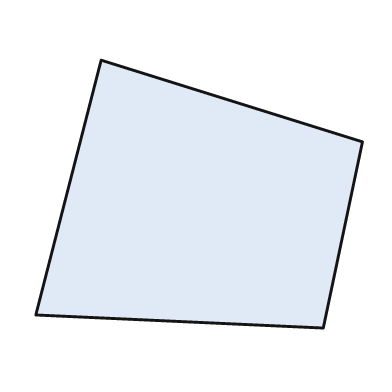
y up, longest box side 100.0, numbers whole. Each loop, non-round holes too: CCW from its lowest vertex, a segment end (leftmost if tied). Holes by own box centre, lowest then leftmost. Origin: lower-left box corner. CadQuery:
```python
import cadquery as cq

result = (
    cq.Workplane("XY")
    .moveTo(88.0, 0.0)
    .lineTo(100.0, 57.0)
    .lineTo(20.0, 82.0)
    .lineTo(0.0, 4.0)
    .close()
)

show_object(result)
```